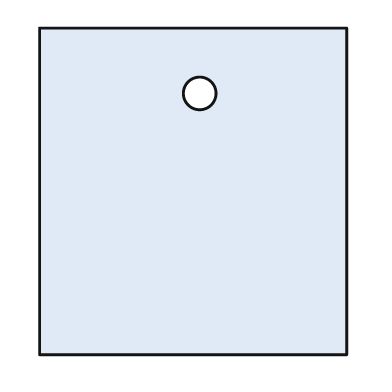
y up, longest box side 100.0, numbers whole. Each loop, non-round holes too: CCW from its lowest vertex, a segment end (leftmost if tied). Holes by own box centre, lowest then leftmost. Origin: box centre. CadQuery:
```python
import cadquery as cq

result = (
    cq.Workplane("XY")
    .moveTo(-47.0, -50.0)
    .lineTo(47.0, -50.0)
    .lineTo(47.0, 50.0)
    .lineTo(-47.0, 50.0)
    .close()
    .moveTo(2.0, 30.0)
    .circle(5.0)
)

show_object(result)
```